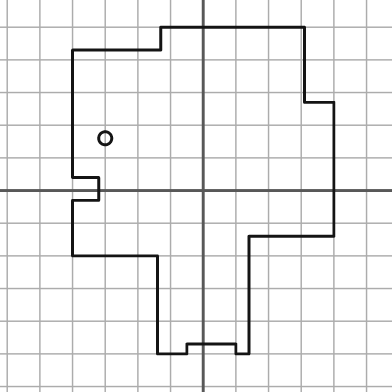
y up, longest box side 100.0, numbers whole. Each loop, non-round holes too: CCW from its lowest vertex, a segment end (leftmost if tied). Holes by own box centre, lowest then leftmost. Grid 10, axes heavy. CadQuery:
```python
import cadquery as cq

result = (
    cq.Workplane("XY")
    .moveTo(-14.0, -50.0)
    .lineTo(-5.0, -50.0)
    .lineTo(-5.0, -47.0)
    .lineTo(10.0, -47.0)
    .lineTo(10.0, -50.0)
    .lineTo(14.0, -50.0)
    .lineTo(14.0, -14.0)
    .lineTo(40.0, -14.0)
    .lineTo(40.0, 27.0)
    .lineTo(31.0, 27.0)
    .lineTo(31.0, 50.0)
    .lineTo(-13.0, 50.0)
    .lineTo(-13.0, 43.0)
    .lineTo(-40.0, 43.0)
    .lineTo(-40.0, 4.0)
    .lineTo(-32.0, 4.0)
    .lineTo(-32.0, -3.0)
    .lineTo(-40.0, -3.0)
    .lineTo(-40.0, -20.0)
    .lineTo(-14.0, -20.0)
    .close()
    .moveTo(-30.0, 16.0)
    .circle(2.0)
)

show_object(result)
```